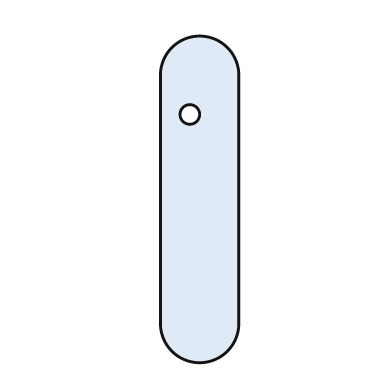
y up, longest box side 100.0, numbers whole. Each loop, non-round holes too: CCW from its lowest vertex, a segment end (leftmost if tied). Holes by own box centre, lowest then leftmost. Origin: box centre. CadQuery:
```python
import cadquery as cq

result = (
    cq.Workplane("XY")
    .moveTo(-12.0, -38.0)
    .threePointArc((0.0, -50.0), (12.0, -38.0))
    .lineTo(12.0, 38.0)
    .threePointArc((0.0, 50.0), (-12.0, 38.0))
    .close()
    .moveTo(-3.0, 26.0)
    .circle(3.0)
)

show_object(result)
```